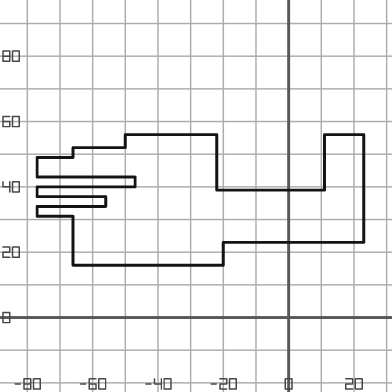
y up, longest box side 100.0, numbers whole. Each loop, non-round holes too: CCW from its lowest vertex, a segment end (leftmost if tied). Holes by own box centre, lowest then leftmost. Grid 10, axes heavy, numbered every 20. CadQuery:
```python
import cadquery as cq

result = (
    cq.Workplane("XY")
    .moveTo(-66.0, 16.0)
    .lineTo(-20.0, 16.0)
    .lineTo(-20.0, 23.0)
    .lineTo(23.0, 23.0)
    .lineTo(23.0, 56.0)
    .lineTo(11.0, 56.0)
    .lineTo(11.0, 39.0)
    .lineTo(-22.0, 39.0)
    .lineTo(-22.0, 56.0)
    .lineTo(-50.0, 56.0)
    .lineTo(-50.0, 52.0)
    .lineTo(-66.0, 52.0)
    .lineTo(-66.0, 49.0)
    .lineTo(-77.0, 49.0)
    .lineTo(-77.0, 43.0)
    .lineTo(-47.0, 43.0)
    .lineTo(-47.0, 40.0)
    .lineTo(-77.0, 40.0)
    .lineTo(-77.0, 37.0)
    .lineTo(-56.0, 37.0)
    .lineTo(-56.0, 34.0)
    .lineTo(-77.0, 34.0)
    .lineTo(-77.0, 31.0)
    .lineTo(-66.0, 31.0)
    .close()
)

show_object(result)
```